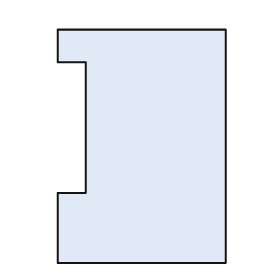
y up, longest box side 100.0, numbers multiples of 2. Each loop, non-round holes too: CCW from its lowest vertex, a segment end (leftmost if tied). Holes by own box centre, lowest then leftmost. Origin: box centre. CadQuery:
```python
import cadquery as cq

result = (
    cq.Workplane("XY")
    .moveTo(-36.0, -50.0)
    .lineTo(36.0, -50.0)
    .lineTo(36.0, 50.0)
    .lineTo(-36.0, 50.0)
    .lineTo(-36.0, 36.0)
    .lineTo(-24.0, 36.0)
    .lineTo(-24.0, -20.0)
    .lineTo(-36.0, -20.0)
    .close()
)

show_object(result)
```